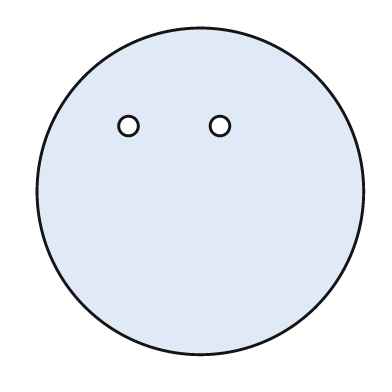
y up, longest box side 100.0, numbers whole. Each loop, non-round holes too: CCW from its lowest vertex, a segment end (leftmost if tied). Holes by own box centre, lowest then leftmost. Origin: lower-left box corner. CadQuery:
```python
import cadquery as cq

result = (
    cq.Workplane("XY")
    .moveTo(50.0, 50.0)
    .circle(50.0)
    .moveTo(28.0, 70.0)
    .circle(3.0)
    .moveTo(56.0, 70.0)
    .circle(3.0)
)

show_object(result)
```